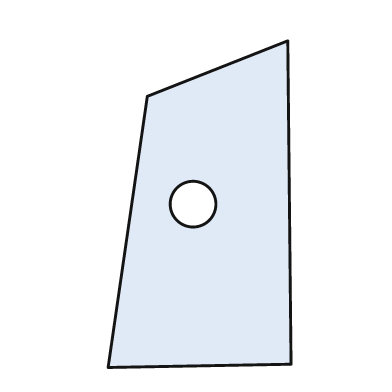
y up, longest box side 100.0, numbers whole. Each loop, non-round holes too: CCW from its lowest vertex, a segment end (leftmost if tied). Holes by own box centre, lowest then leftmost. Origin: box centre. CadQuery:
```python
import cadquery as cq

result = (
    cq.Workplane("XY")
    .moveTo(-28.0, -50.0)
    .lineTo(28.0, -49.0)
    .lineTo(27.0, 50.0)
    .lineTo(-16.0, 33.0)
    .close()
    .moveTo(-2.0, 0.0)
    .circle(7.0)
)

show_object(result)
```